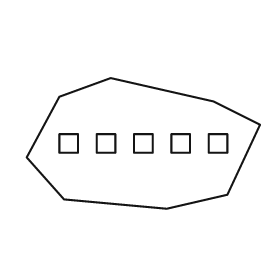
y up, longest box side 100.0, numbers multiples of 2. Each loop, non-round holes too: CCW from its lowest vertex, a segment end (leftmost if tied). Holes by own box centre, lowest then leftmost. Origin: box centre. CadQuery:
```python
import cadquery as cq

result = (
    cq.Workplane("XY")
    .moveTo(10.0, -28.0)
    .lineTo(36.0, -22.0)
    .lineTo(50.0, 8.0)
    .lineTo(30.0, 18.0)
    .lineTo(-14.0, 28.0)
    .lineTo(-36.0, 20.0)
    .lineTo(-50.0, -6.0)
    .lineTo(-34.0, -24.0)
    .close()
    .moveTo(-36.0, -4.0)
    .lineTo(-28.0, -4.0)
    .lineTo(-28.0, 4.0)
    .lineTo(-36.0, 4.0)
    .close()
    .moveTo(-20.0, -4.0)
    .lineTo(-12.0, -4.0)
    .lineTo(-12.0, 4.0)
    .lineTo(-20.0, 4.0)
    .close()
    .moveTo(-4.0, -4.0)
    .lineTo(4.0, -4.0)
    .lineTo(4.0, 4.0)
    .lineTo(-4.0, 4.0)
    .close()
    .moveTo(12.0, -4.0)
    .lineTo(20.0, -4.0)
    .lineTo(20.0, 4.0)
    .lineTo(12.0, 4.0)
    .close()
    .moveTo(28.0, -4.0)
    .lineTo(36.0, -4.0)
    .lineTo(36.0, 4.0)
    .lineTo(28.0, 4.0)
    .close()
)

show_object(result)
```